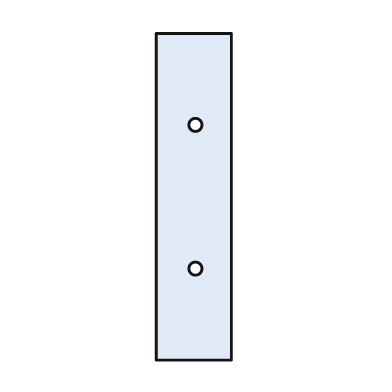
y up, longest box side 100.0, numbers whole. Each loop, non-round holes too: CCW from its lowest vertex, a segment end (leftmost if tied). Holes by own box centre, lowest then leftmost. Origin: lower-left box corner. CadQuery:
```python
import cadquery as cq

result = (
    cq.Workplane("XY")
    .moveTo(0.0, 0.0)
    .lineTo(23.0, 0.0)
    .lineTo(23.0, 100.0)
    .lineTo(0.0, 100.0)
    .close()
    .moveTo(12.0, 28.0)
    .circle(2.0)
    .moveTo(12.0, 72.0)
    .circle(2.0)
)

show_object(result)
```